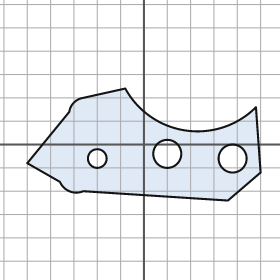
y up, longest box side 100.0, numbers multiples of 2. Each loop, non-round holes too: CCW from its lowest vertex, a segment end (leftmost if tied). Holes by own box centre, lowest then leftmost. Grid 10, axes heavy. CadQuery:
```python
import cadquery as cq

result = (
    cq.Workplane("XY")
    .moveTo(36.0, -24.0)
    .lineTo(50.0, -12.0)
    .lineTo(48.0, 16.0)
    .threePointArc((18.0, 6.0), (-8.0, 24.0))
    .lineTo(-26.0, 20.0)
    .threePointArc((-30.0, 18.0), (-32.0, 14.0))
    .lineTo(-50.0, -8.0)
    .lineTo(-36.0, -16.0)
    .threePointArc((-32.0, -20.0), (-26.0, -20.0))
    .close()
    .moveTo(-20.0, -6.0)
    .circle(4.0)
    .moveTo(38.0, -6.0)
    .circle(6.0)
    .moveTo(10.0, -4.0)
    .circle(6.0)
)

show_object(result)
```